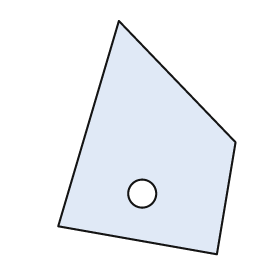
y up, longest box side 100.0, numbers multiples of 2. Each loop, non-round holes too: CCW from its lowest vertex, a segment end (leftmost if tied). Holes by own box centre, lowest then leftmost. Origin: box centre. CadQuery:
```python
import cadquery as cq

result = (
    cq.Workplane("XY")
    .moveTo(30.0, -50.0)
    .lineTo(38.0, -2.0)
    .lineTo(-12.0, 50.0)
    .lineTo(-38.0, -38.0)
    .close()
    .moveTo(-2.0, -24.0)
    .circle(6.0)
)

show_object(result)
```